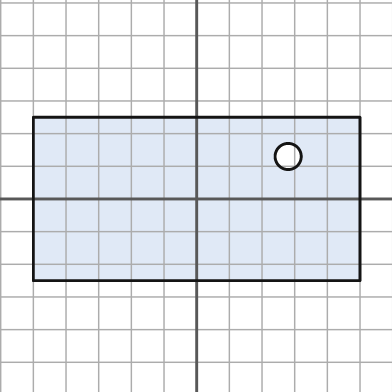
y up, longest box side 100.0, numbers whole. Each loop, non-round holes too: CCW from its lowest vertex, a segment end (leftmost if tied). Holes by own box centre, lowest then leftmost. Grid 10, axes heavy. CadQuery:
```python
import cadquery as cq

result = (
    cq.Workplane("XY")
    .moveTo(-50.0, -25.0)
    .lineTo(50.0, -25.0)
    .lineTo(50.0, 25.0)
    .lineTo(-50.0, 25.0)
    .close()
    .moveTo(28.0, 13.0)
    .circle(4.0)
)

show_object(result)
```